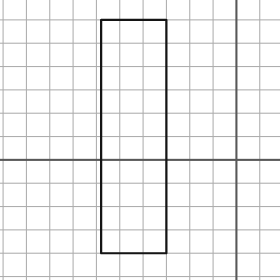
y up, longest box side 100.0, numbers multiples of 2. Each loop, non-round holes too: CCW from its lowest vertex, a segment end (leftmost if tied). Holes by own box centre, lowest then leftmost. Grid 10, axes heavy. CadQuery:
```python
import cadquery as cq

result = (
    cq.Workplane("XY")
    .moveTo(-58.0, -40.0)
    .lineTo(-30.0, -40.0)
    .lineTo(-30.0, 60.0)
    .lineTo(-58.0, 60.0)
    .close()
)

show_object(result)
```